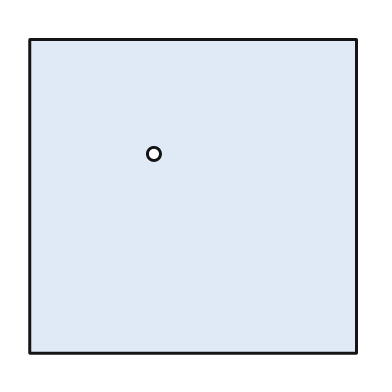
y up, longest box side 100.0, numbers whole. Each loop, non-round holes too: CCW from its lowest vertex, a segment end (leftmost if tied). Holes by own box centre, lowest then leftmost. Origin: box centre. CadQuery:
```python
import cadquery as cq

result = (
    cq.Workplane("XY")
    .moveTo(-50.0, -48.0)
    .lineTo(50.0, -48.0)
    .lineTo(50.0, 48.0)
    .lineTo(-50.0, 48.0)
    .close()
    .moveTo(-12.0, 13.0)
    .circle(2.0)
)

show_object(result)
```